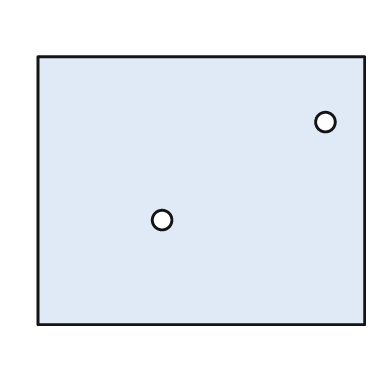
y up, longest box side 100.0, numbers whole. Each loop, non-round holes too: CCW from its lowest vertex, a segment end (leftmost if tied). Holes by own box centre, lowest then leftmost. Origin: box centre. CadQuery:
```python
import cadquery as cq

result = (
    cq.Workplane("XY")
    .moveTo(-50.0, -41.0)
    .lineTo(50.0, -41.0)
    .lineTo(50.0, 41.0)
    .lineTo(-50.0, 41.0)
    .close()
    .moveTo(-12.0, -9.0)
    .circle(3.0)
    .moveTo(38.0, 21.0)
    .circle(3.0)
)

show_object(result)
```